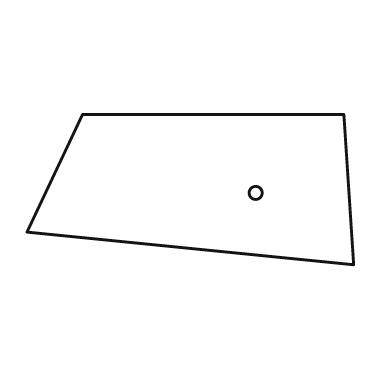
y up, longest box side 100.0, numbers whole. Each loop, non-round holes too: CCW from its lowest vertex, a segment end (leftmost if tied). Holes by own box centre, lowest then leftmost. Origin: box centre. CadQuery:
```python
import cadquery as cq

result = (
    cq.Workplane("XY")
    .moveTo(50.0, -23.0)
    .lineTo(47.0, 23.0)
    .lineTo(-33.0, 23.0)
    .lineTo(-50.0, -13.0)
    .close()
    .moveTo(20.0, -1.0)
    .circle(2.0)
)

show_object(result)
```